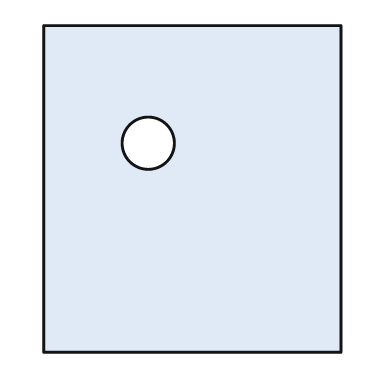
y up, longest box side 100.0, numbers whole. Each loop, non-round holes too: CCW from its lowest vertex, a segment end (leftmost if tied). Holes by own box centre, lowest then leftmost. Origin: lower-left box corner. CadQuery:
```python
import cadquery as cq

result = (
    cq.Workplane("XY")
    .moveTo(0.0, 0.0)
    .lineTo(91.0, 0.0)
    .lineTo(91.0, 100.0)
    .lineTo(0.0, 100.0)
    .close()
    .moveTo(32.0, 64.0)
    .circle(8.0)
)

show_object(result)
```